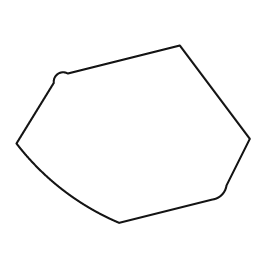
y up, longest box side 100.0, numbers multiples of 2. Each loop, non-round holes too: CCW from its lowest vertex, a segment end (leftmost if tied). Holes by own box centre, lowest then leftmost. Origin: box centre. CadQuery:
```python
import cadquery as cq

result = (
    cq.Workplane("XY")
    .moveTo(-6.0, -38.0)
    .lineTo(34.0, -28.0)
    .threePointArc((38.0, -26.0), (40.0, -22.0))
    .lineTo(50.0, -2.0)
    .lineTo(20.0, 38.0)
    .lineTo(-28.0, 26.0)
    .threePointArc((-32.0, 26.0), (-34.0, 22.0))
    .lineTo(-50.0, -4.0)
    .threePointArc((-30.0, -24.0), (-6.0, -38.0))
    .close()
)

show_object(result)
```